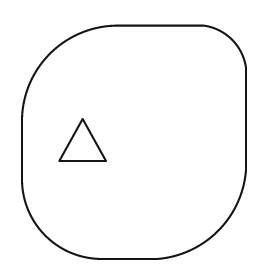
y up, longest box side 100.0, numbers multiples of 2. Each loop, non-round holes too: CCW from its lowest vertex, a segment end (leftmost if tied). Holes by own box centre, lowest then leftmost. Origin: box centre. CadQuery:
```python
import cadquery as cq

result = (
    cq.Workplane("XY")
    .moveTo(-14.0, -50.0)
    .lineTo(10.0, -50.0)
    .threePointArc((36.0, -38.0), (48.0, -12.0))
    .lineTo(48.0, 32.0)
    .threePointArc((42.0, 44.0), (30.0, 50.0))
    .lineTo(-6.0, 50.0)
    .threePointArc((-36.0, 38.0), (-48.0, 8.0))
    .lineTo(-48.0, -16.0)
    .threePointArc((-38.0, -40.0), (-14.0, -50.0))
    .close()
    .moveTo(-32.0, -8.0)
    .lineTo(-12.0, -8.0)
    .lineTo(-22.0, 10.0)
    .close()
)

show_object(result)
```